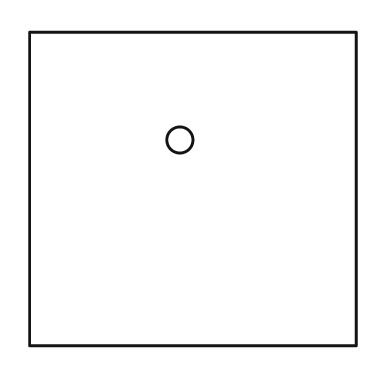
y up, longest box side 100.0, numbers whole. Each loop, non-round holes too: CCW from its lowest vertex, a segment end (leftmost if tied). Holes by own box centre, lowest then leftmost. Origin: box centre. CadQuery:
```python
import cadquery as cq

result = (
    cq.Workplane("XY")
    .moveTo(-50.0, -48.0)
    .lineTo(50.0, -48.0)
    .lineTo(50.0, 48.0)
    .lineTo(-50.0, 48.0)
    .close()
    .moveTo(-4.0, 15.0)
    .circle(4.0)
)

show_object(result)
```